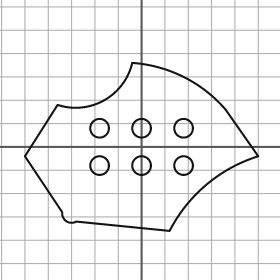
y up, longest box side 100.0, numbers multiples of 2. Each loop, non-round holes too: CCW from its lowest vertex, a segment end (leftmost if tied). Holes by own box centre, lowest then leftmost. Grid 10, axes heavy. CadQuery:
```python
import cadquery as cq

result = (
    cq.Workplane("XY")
    .moveTo(12.0, -36.0)
    .threePointArc((28.0, -16.0), (50.0, -4.0))
    .lineTo(36.0, 16.0)
    .threePointArc((18.0, 30.0), (-4.0, 36.0))
    .threePointArc((-16.0, 20.0), (-36.0, 18.0))
    .lineTo(-50.0, -4.0)
    .lineTo(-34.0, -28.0)
    .threePointArc((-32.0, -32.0), (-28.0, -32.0))
    .close()
    .moveTo(-18.0, -8.0)
    .circle(4.0)
    .moveTo(0.0, -8.0)
    .circle(4.0)
    .moveTo(18.0, -8.0)
    .circle(4.0)
    .moveTo(-18.0, 8.0)
    .circle(4.0)
    .moveTo(0.0, 8.0)
    .circle(4.0)
    .moveTo(18.0, 8.0)
    .circle(4.0)
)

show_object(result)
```